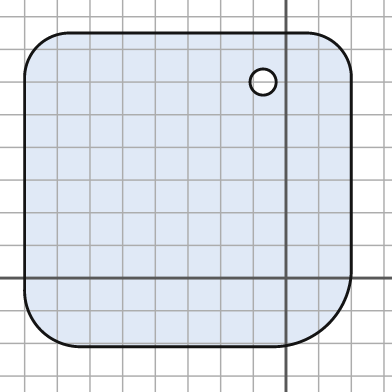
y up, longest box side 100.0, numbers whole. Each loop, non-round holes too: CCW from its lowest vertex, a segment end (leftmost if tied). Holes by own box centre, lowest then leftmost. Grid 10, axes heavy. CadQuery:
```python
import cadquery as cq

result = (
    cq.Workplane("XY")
    .moveTo(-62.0, -21.0)
    .lineTo(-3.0, -21.0)
    .threePointArc((13.0, -14.0), (20.0, 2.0))
    .lineTo(20.0, 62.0)
    .threePointArc((16.0, 71.0), (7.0, 75.0))
    .lineTo(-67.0, 75.0)
    .threePointArc((-76.0, 71.0), (-80.0, 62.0))
    .lineTo(-80.0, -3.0)
    .threePointArc((-75.0, -16.0), (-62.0, -21.0))
    .close()
    .moveTo(-7.0, 60.0)
    .circle(4.0)
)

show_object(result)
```